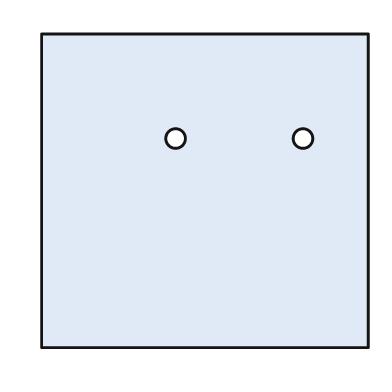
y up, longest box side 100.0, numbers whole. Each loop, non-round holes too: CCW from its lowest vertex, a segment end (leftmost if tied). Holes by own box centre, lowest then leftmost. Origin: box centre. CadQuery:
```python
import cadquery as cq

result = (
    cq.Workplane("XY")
    .moveTo(-50.0, -48.0)
    .lineTo(50.0, -48.0)
    .lineTo(50.0, 48.0)
    .lineTo(-50.0, 48.0)
    .close()
    .moveTo(-9.0, 16.0)
    .circle(3.0)
    .moveTo(30.0, 16.0)
    .circle(3.0)
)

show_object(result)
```